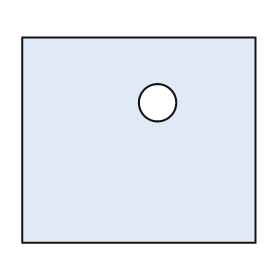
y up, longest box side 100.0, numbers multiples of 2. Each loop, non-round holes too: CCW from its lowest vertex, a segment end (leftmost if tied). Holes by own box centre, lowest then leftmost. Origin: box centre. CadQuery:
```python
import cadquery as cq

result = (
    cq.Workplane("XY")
    .moveTo(-50.0, -44.0)
    .lineTo(50.0, -44.0)
    .lineTo(50.0, 44.0)
    .lineTo(-50.0, 44.0)
    .close()
    .moveTo(8.0, 16.0)
    .circle(8.0)
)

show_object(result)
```